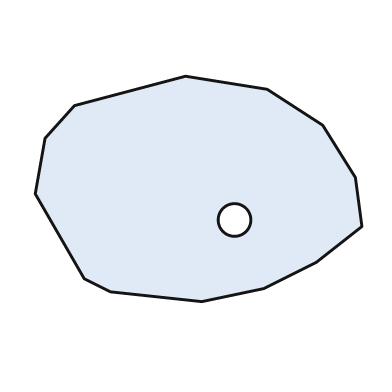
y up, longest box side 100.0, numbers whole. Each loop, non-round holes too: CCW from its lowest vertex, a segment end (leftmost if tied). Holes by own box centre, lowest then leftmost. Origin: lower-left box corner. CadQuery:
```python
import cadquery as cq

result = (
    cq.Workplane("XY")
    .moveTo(51.0, 0.0)
    .lineTo(70.0, 4.0)
    .lineTo(86.0, 12.0)
    .lineTo(100.0, 23.0)
    .lineTo(98.0, 38.0)
    .lineTo(88.0, 54.0)
    .lineTo(71.0, 65.0)
    .lineTo(46.0, 69.0)
    .lineTo(12.0, 60.0)
    .lineTo(3.0, 50.0)
    .lineTo(0.0, 33.0)
    .lineTo(15.0, 7.0)
    .lineTo(23.0, 3.0)
    .close()
    .moveTo(61.0, 25.0)
    .circle(5.0)
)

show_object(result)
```